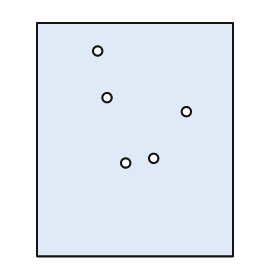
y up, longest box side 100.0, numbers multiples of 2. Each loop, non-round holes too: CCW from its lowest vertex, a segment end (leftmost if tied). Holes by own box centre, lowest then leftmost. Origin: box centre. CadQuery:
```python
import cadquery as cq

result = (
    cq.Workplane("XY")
    .moveTo(-42.0, -50.0)
    .lineTo(42.0, -50.0)
    .lineTo(42.0, 50.0)
    .lineTo(-42.0, 50.0)
    .close()
    .moveTo(-4.0, -10.0)
    .circle(2.0)
    .moveTo(8.0, -8.0)
    .circle(2.0)
    .moveTo(22.0, 12.0)
    .circle(2.0)
    .moveTo(-12.0, 18.0)
    .circle(2.0)
    .moveTo(-16.0, 38.0)
    .circle(2.0)
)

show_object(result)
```